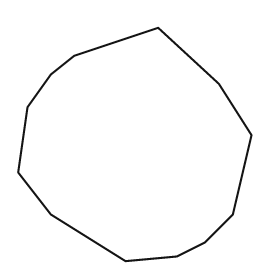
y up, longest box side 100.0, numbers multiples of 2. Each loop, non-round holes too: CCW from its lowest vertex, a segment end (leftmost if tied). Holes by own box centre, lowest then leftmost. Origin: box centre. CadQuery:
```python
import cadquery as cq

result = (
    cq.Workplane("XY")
    .moveTo(-4.0, -50.0)
    .lineTo(18.0, -48.0)
    .lineTo(30.0, -42.0)
    .lineTo(42.0, -30.0)
    .lineTo(50.0, 4.0)
    .lineTo(36.0, 26.0)
    .lineTo(10.0, 50.0)
    .lineTo(-26.0, 38.0)
    .lineTo(-36.0, 30.0)
    .lineTo(-46.0, 16.0)
    .lineTo(-50.0, -12.0)
    .lineTo(-36.0, -30.0)
    .close()
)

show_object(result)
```